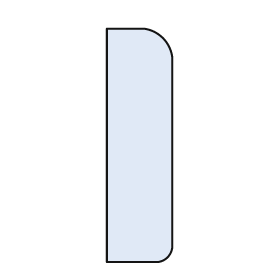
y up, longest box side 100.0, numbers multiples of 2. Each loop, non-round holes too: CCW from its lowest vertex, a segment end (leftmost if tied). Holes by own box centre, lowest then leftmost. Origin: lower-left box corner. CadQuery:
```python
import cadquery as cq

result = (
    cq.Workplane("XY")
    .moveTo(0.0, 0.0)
    .lineTo(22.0, 0.0)
    .threePointArc((26.0, 2.0), (28.0, 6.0))
    .lineTo(28.0, 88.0)
    .threePointArc((24.0, 96.0), (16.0, 100.0))
    .lineTo(0.0, 100.0)
    .close()
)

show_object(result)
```